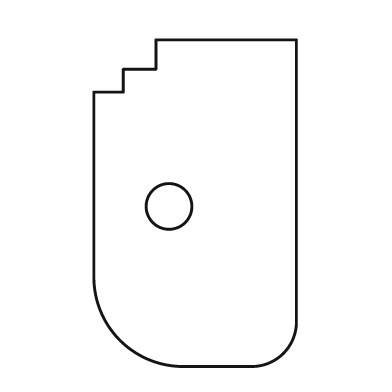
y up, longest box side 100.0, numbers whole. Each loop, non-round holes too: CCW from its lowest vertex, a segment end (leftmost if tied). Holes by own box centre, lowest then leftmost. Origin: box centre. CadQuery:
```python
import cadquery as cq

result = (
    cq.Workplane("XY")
    .moveTo(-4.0, -50.0)
    .lineTo(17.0, -50.0)
    .threePointArc((27.0, -46.0), (31.0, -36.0))
    .lineTo(31.0, 50.0)
    .lineTo(-12.0, 50.0)
    .lineTo(-12.0, 41.0)
    .lineTo(-22.0, 41.0)
    .lineTo(-22.0, 34.0)
    .lineTo(-31.0, 34.0)
    .lineTo(-31.0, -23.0)
    .threePointArc((-23.0, -42.0), (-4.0, -50.0))
    .close()
    .moveTo(-8.0, -1.0)
    .circle(7.0)
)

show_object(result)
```